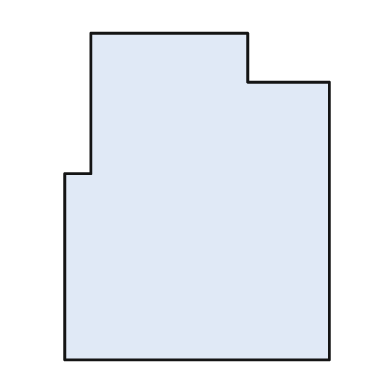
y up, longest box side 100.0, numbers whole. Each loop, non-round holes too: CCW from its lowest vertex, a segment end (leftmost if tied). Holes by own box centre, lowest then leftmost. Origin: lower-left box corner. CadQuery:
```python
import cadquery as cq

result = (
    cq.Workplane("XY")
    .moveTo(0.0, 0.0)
    .lineTo(81.0, 0.0)
    .lineTo(81.0, 85.0)
    .lineTo(56.0, 85.0)
    .lineTo(56.0, 100.0)
    .lineTo(8.0, 100.0)
    .lineTo(8.0, 57.0)
    .lineTo(0.0, 57.0)
    .close()
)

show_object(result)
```